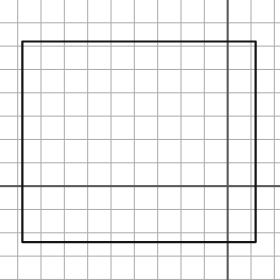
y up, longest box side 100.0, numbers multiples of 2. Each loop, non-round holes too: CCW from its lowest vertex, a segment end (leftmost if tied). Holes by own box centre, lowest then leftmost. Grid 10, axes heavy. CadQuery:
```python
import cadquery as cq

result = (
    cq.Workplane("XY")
    .moveTo(-88.0, -24.0)
    .lineTo(12.0, -24.0)
    .lineTo(12.0, 62.0)
    .lineTo(-88.0, 62.0)
    .close()
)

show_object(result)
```